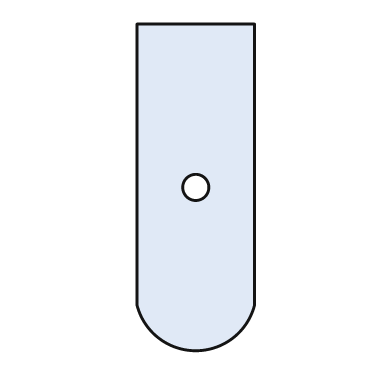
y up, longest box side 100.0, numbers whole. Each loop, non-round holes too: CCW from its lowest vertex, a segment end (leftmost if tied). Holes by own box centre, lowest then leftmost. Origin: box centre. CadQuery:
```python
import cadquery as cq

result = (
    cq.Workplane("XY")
    .moveTo(-18.0, -36.0)
    .threePointArc((0.0, -50.0), (18.0, -36.0))
    .lineTo(18.0, 50.0)
    .lineTo(-18.0, 50.0)
    .close()
    .moveTo(0.0, 0.0)
    .circle(4.0)
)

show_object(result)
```